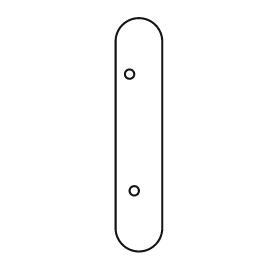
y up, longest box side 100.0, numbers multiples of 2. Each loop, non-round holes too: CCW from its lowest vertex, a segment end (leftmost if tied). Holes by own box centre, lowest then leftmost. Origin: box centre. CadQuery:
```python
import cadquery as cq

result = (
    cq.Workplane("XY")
    .moveTo(-10.0, -40.0)
    .threePointArc((0.0, -50.0), (10.0, -40.0))
    .lineTo(10.0, 40.0)
    .threePointArc((0.0, 50.0), (-10.0, 40.0))
    .close()
    .moveTo(-2.0, -24.0)
    .circle(2.0)
    .moveTo(-4.0, 26.0)
    .circle(2.0)
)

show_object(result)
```